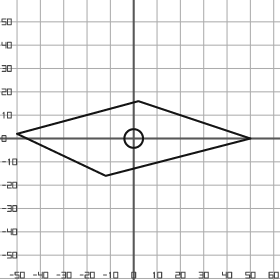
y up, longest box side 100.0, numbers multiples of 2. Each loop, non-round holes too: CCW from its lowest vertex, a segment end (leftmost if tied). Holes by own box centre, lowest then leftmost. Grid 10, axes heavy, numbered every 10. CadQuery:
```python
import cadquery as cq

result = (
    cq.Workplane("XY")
    .moveTo(-12.0, -16.0)
    .lineTo(50.0, 0.0)
    .lineTo(2.0, 16.0)
    .lineTo(-50.0, 2.0)
    .close()
    .moveTo(0.0, 0.0)
    .circle(4.0)
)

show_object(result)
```